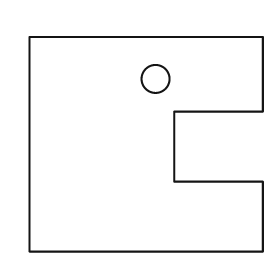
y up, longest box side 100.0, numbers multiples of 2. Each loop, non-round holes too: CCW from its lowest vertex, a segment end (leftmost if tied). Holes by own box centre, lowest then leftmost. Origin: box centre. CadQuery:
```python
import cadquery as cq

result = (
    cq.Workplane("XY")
    .moveTo(-50.0, -46.0)
    .lineTo(50.0, -46.0)
    .lineTo(50.0, -16.0)
    .lineTo(12.0, -16.0)
    .lineTo(12.0, 14.0)
    .lineTo(50.0, 14.0)
    .lineTo(50.0, 46.0)
    .lineTo(-50.0, 46.0)
    .close()
    .moveTo(4.0, 28.0)
    .circle(6.0)
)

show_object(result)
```